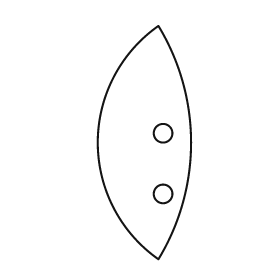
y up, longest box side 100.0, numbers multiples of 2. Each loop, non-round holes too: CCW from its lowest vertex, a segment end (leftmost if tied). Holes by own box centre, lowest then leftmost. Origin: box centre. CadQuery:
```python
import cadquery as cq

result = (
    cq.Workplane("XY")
    .moveTo(6.0, -50.0)
    .threePointArc((20.0, 0.0), (6.0, 50.0))
    .threePointArc((-20.0, 0.0), (6.0, -50.0))
    .close()
    .moveTo(8.0, -22.0)
    .circle(4.0)
    .moveTo(8.0, 4.0)
    .circle(4.0)
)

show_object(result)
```